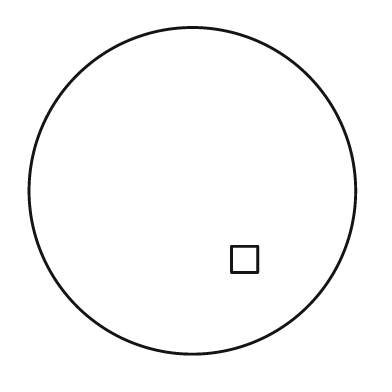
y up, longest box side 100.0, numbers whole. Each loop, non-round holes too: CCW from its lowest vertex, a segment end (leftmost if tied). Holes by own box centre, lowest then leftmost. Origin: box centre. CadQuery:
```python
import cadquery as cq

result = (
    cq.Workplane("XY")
    .moveTo(0.0, 0.0)
    .circle(50.0)
    .moveTo(12.0, -25.0)
    .lineTo(20.0, -25.0)
    .lineTo(20.0, -17.0)
    .lineTo(12.0, -17.0)
    .close()
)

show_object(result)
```